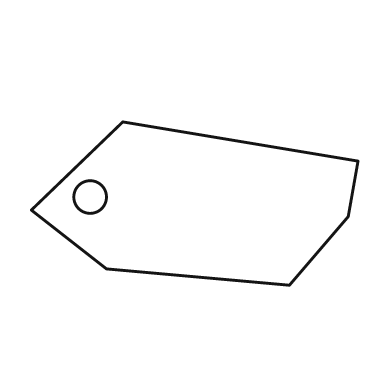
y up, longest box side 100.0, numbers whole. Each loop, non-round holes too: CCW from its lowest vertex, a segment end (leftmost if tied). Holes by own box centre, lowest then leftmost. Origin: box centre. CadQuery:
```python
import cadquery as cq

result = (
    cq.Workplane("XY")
    .moveTo(29.0, -25.0)
    .lineTo(47.0, -4.0)
    .lineTo(50.0, 13.0)
    .lineTo(-22.0, 25.0)
    .lineTo(-50.0, -2.0)
    .lineTo(-27.0, -20.0)
    .close()
    .moveTo(-32.0, 2.0)
    .circle(5.0)
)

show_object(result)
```